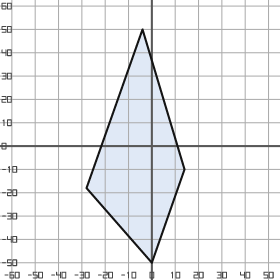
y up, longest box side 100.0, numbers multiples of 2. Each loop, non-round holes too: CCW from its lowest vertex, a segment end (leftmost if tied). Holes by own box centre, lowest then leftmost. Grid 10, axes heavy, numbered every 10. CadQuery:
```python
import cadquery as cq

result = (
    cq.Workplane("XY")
    .moveTo(0.0, -50.0)
    .lineTo(14.0, -10.0)
    .lineTo(-4.0, 50.0)
    .lineTo(-28.0, -18.0)
    .close()
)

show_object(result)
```